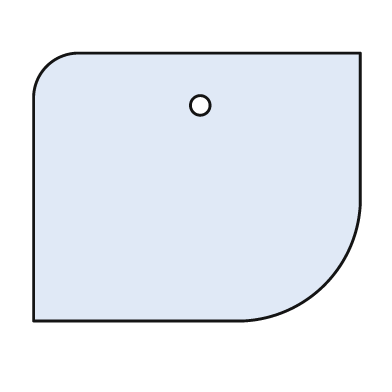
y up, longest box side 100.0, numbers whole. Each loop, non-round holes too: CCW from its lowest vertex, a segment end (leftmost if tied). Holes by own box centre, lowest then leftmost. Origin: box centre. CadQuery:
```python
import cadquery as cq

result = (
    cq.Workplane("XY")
    .moveTo(-50.0, -41.0)
    .lineTo(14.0, -41.0)
    .threePointArc((39.0, -30.0), (50.0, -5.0))
    .lineTo(50.0, 41.0)
    .lineTo(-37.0, 41.0)
    .threePointArc((-46.0, 37.0), (-50.0, 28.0))
    .close()
    .moveTo(1.0, 25.0)
    .circle(3.0)
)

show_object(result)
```